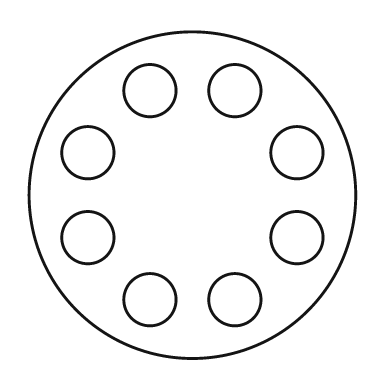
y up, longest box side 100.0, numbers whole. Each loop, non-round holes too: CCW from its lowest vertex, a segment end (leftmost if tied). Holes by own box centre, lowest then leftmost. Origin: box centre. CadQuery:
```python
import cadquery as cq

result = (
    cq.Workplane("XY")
    .moveTo(0.0, 0.0)
    .circle(50.0)
    .moveTo(-13.0, -32.0)
    .circle(8.0)
    .moveTo(13.0, -32.0)
    .circle(8.0)
    .moveTo(-32.0, -13.0)
    .circle(8.0)
    .moveTo(32.0, -13.0)
    .circle(8.0)
    .moveTo(-32.0, 13.0)
    .circle(8.0)
    .moveTo(32.0, 13.0)
    .circle(8.0)
    .moveTo(-13.0, 32.0)
    .circle(8.0)
    .moveTo(13.0, 32.0)
    .circle(8.0)
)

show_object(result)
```